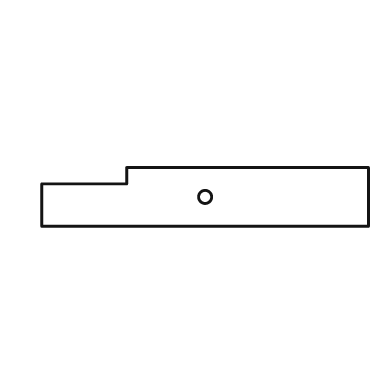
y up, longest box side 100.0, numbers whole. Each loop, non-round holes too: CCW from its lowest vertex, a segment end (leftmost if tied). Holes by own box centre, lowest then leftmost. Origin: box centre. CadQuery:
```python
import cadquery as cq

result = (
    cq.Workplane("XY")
    .moveTo(-50.0, -9.0)
    .lineTo(50.0, -9.0)
    .lineTo(50.0, 9.0)
    .lineTo(-24.0, 9.0)
    .lineTo(-24.0, 4.0)
    .lineTo(-50.0, 4.0)
    .close()
    .moveTo(0.0, 0.0)
    .circle(2.0)
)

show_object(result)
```